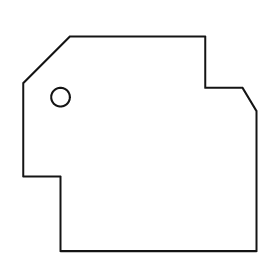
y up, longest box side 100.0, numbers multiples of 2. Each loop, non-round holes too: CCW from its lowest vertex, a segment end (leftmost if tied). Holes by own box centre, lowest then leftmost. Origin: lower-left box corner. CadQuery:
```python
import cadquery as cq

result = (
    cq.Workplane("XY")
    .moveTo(16.0, 0.0)
    .lineTo(100.0, 0.0)
    .lineTo(100.0, 60.0)
    .lineTo(94.0, 70.0)
    .lineTo(78.0, 70.0)
    .lineTo(78.0, 92.0)
    .lineTo(20.0, 92.0)
    .lineTo(0.0, 72.0)
    .lineTo(0.0, 32.0)
    .lineTo(16.0, 32.0)
    .close()
    .moveTo(16.0, 66.0)
    .circle(4.0)
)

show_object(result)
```